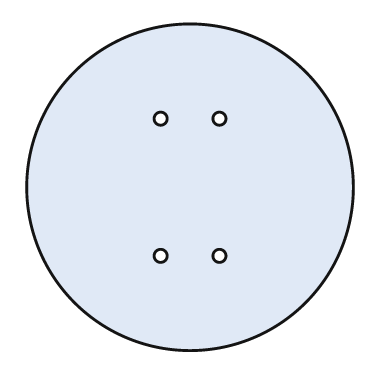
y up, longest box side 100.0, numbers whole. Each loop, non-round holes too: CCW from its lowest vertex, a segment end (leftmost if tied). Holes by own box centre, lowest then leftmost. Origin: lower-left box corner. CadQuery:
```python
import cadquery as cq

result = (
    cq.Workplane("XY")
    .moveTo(50.0, 50.0)
    .circle(50.0)
    .moveTo(41.0, 29.0)
    .circle(2.0)
    .moveTo(59.0, 29.0)
    .circle(2.0)
    .moveTo(41.0, 71.0)
    .circle(2.0)
    .moveTo(59.0, 71.0)
    .circle(2.0)
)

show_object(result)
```